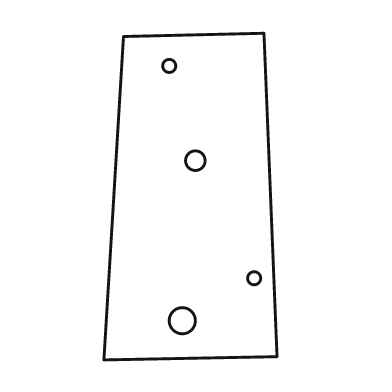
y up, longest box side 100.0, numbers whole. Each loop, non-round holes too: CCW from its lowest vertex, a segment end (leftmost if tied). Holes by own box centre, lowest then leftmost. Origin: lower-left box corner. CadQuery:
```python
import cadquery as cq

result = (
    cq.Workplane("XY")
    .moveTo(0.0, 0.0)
    .lineTo(53.0, 1.0)
    .lineTo(49.0, 100.0)
    .lineTo(6.0, 99.0)
    .close()
    .moveTo(24.0, 12.0)
    .circle(4.0)
    .moveTo(46.0, 25.0)
    .circle(2.0)
    .moveTo(28.0, 61.0)
    .circle(3.0)
    .moveTo(20.0, 90.0)
    .circle(2.0)
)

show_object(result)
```